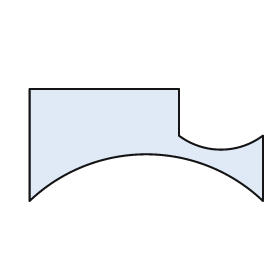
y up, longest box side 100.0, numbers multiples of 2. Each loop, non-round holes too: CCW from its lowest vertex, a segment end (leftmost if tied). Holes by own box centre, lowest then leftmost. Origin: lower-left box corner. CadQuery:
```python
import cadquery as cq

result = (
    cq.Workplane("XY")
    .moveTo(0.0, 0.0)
    .threePointArc((50.0, 20.0), (100.0, 0.0))
    .lineTo(100.0, 28.0)
    .threePointArc((82.0, 22.0), (64.0, 28.0))
    .lineTo(64.0, 48.0)
    .lineTo(0.0, 48.0)
    .close()
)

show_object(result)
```